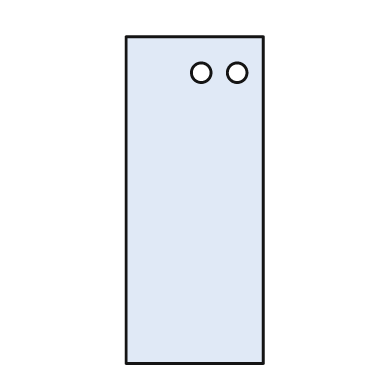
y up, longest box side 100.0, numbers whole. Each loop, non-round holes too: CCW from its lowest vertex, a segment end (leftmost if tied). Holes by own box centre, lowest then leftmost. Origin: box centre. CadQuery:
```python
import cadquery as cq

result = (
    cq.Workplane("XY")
    .moveTo(-21.0, -50.0)
    .lineTo(21.0, -50.0)
    .lineTo(21.0, 50.0)
    .lineTo(-21.0, 50.0)
    .close()
    .moveTo(2.0, 39.0)
    .circle(3.0)
    .moveTo(13.0, 39.0)
    .circle(3.0)
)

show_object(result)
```